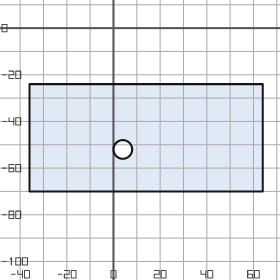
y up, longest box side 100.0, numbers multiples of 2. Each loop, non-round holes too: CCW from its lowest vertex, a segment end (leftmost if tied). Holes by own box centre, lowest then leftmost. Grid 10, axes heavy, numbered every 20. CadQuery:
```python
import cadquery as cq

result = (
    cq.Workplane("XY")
    .moveTo(-36.0, -70.0)
    .lineTo(64.0, -70.0)
    .lineTo(64.0, -24.0)
    .lineTo(-36.0, -24.0)
    .close()
    .moveTo(4.0, -52.0)
    .circle(4.0)
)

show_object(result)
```